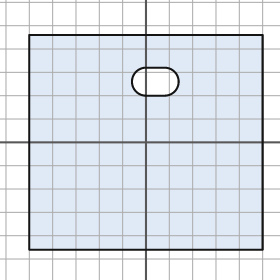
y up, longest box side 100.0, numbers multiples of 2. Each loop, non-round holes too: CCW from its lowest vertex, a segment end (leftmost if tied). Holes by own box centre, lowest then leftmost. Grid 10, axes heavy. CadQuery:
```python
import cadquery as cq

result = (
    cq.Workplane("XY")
    .moveTo(-50.0, -46.0)
    .lineTo(50.0, -46.0)
    .lineTo(50.0, 46.0)
    .lineTo(-50.0, 46.0)
    .close()
    .moveTo(0.0, 20.0)
    .lineTo(8.0, 20.0)
    .threePointArc((14.0, 26.0), (8.0, 32.0))
    .lineTo(0.0, 32.0)
    .threePointArc((-6.0, 26.0), (0.0, 20.0))
    .close()
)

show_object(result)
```